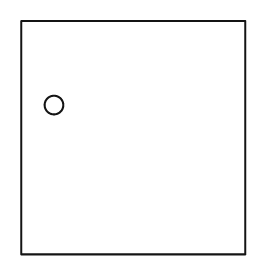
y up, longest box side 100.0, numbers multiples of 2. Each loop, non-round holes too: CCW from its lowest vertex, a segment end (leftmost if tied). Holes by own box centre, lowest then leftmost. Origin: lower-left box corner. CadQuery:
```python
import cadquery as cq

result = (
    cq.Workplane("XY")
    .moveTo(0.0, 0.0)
    .lineTo(96.0, 0.0)
    .lineTo(96.0, 100.0)
    .lineTo(0.0, 100.0)
    .close()
    .moveTo(14.0, 64.0)
    .circle(4.0)
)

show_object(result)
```